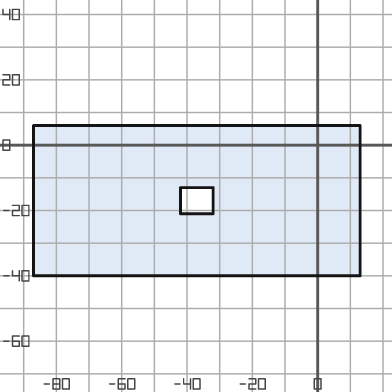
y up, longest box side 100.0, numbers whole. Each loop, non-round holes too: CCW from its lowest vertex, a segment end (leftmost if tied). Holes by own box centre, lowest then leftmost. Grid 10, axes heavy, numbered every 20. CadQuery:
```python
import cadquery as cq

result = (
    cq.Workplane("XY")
    .moveTo(-87.0, -40.0)
    .lineTo(13.0, -40.0)
    .lineTo(13.0, 6.0)
    .lineTo(-87.0, 6.0)
    .close()
    .moveTo(-42.0, -21.0)
    .lineTo(-32.0, -21.0)
    .lineTo(-32.0, -13.0)
    .lineTo(-42.0, -13.0)
    .close()
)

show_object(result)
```